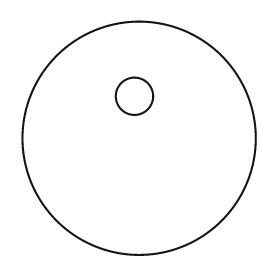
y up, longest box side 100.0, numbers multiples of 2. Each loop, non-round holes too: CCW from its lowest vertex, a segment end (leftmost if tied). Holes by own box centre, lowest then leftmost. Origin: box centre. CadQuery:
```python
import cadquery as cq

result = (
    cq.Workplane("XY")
    .moveTo(0.0, 0.0)
    .circle(50.0)
    .moveTo(-2.0, 18.0)
    .circle(8.0)
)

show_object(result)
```